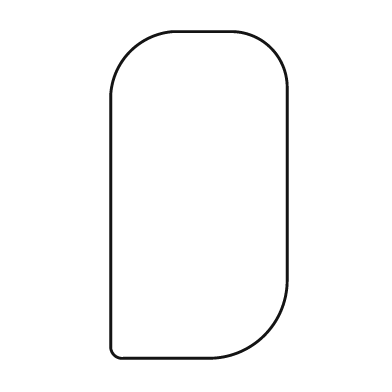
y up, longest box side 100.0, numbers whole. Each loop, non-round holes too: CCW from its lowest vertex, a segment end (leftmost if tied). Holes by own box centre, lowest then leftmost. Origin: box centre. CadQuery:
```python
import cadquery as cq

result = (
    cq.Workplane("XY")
    .moveTo(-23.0, -50.0)
    .lineTo(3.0, -50.0)
    .threePointArc((20.0, -43.0), (27.0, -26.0))
    .lineTo(27.0, 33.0)
    .threePointArc((22.0, 45.0), (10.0, 50.0))
    .lineTo(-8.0, 50.0)
    .threePointArc((-21.0, 44.0), (-27.0, 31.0))
    .lineTo(-27.0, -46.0)
    .threePointArc((-26.0, -49.0), (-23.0, -50.0))
    .close()
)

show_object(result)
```